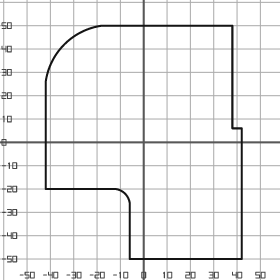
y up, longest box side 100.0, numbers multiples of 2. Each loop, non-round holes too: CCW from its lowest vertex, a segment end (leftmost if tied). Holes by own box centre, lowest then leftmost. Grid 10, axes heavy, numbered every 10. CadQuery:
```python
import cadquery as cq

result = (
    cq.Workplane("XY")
    .moveTo(-6.0, -50.0)
    .lineTo(42.0, -50.0)
    .lineTo(42.0, 6.0)
    .lineTo(38.0, 6.0)
    .lineTo(38.0, 50.0)
    .lineTo(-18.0, 50.0)
    .threePointArc((-34.0, 42.0), (-42.0, 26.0))
    .lineTo(-42.0, -20.0)
    .lineTo(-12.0, -20.0)
    .threePointArc((-8.0, -22.0), (-6.0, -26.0))
    .close()
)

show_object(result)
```